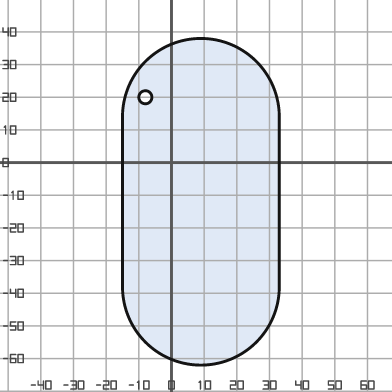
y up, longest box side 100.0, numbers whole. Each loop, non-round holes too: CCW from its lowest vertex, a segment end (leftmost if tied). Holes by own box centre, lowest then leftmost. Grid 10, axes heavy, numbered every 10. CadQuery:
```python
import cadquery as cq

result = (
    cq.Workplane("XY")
    .moveTo(-15.0, -38.0)
    .threePointArc((9.0, -62.0), (33.0, -38.0))
    .lineTo(33.0, 14.0)
    .threePointArc((9.0, 38.0), (-15.0, 14.0))
    .close()
    .moveTo(-8.0, 20.0)
    .circle(2.0)
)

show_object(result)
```